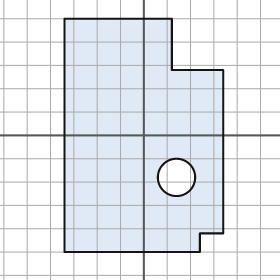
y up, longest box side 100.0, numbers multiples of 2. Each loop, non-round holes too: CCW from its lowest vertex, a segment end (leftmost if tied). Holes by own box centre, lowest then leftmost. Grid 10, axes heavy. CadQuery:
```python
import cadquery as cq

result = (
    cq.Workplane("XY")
    .moveTo(-34.0, -50.0)
    .lineTo(24.0, -50.0)
    .lineTo(24.0, -42.0)
    .lineTo(34.0, -42.0)
    .lineTo(34.0, 28.0)
    .lineTo(12.0, 28.0)
    .lineTo(12.0, 50.0)
    .lineTo(-34.0, 50.0)
    .close()
    .moveTo(14.0, -18.0)
    .circle(8.0)
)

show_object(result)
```